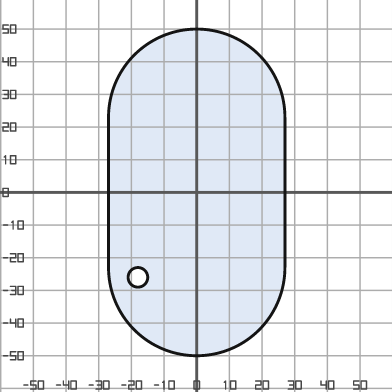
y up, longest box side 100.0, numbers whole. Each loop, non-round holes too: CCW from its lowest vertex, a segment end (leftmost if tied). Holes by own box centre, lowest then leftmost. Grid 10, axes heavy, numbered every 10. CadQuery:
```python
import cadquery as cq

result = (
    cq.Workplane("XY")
    .moveTo(-27.0, -23.0)
    .threePointArc((0.0, -50.0), (27.0, -23.0))
    .lineTo(27.0, 23.0)
    .threePointArc((0.0, 50.0), (-27.0, 23.0))
    .close()
    .moveTo(-18.0, -26.0)
    .circle(3.0)
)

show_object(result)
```